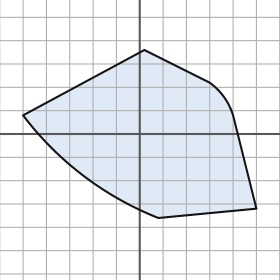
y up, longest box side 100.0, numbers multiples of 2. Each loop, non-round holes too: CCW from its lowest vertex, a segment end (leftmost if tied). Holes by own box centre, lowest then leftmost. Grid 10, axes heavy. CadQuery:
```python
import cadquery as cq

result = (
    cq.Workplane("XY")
    .moveTo(8.0, -36.0)
    .lineTo(50.0, -32.0)
    .lineTo(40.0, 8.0)
    .threePointArc((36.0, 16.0), (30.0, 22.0))
    .lineTo(2.0, 36.0)
    .lineTo(-50.0, 8.0)
    .threePointArc((-24.0, -18.0), (8.0, -36.0))
    .close()
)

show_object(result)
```